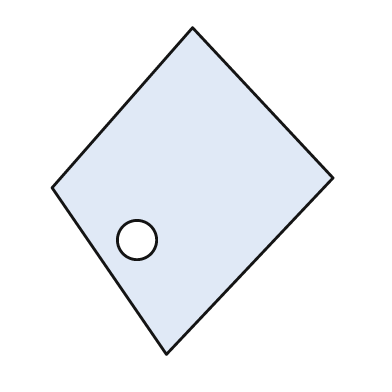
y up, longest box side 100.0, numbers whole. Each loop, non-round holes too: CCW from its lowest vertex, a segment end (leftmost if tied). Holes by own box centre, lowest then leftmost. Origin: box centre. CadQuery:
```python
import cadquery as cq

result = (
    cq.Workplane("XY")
    .moveTo(-8.0, -50.0)
    .lineTo(43.0, 4.0)
    .lineTo(0.0, 50.0)
    .lineTo(-43.0, 1.0)
    .close()
    .moveTo(-17.0, -15.0)
    .circle(6.0)
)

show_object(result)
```